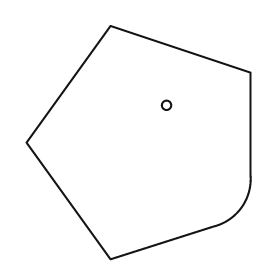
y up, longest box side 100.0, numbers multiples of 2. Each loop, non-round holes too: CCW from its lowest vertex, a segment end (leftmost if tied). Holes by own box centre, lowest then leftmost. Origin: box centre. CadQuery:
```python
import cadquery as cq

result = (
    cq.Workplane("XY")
    .moveTo(-12.0, -50.0)
    .lineTo(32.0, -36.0)
    .threePointArc((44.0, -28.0), (48.0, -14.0))
    .lineTo(48.0, 30.0)
    .lineTo(-12.0, 50.0)
    .lineTo(-48.0, 0.0)
    .close()
    .moveTo(12.0, 16.0)
    .circle(2.0)
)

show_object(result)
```